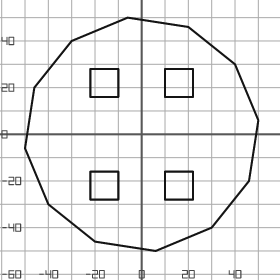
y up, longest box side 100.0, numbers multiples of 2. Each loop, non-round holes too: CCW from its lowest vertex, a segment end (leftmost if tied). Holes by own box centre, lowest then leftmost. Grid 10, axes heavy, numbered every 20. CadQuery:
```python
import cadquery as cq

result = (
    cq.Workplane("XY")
    .moveTo(6.0, -50.0)
    .lineTo(30.0, -40.0)
    .lineTo(46.0, -20.0)
    .lineTo(50.0, 6.0)
    .lineTo(40.0, 30.0)
    .lineTo(20.0, 46.0)
    .lineTo(-6.0, 50.0)
    .lineTo(-30.0, 40.0)
    .lineTo(-46.0, 20.0)
    .lineTo(-50.0, -6.0)
    .lineTo(-40.0, -30.0)
    .lineTo(-20.0, -46.0)
    .close()
    .moveTo(-22.0, -28.0)
    .lineTo(-10.0, -28.0)
    .lineTo(-10.0, -16.0)
    .lineTo(-22.0, -16.0)
    .close()
    .moveTo(10.0, -28.0)
    .lineTo(22.0, -28.0)
    .lineTo(22.0, -16.0)
    .lineTo(10.0, -16.0)
    .close()
    .moveTo(-22.0, 16.0)
    .lineTo(-10.0, 16.0)
    .lineTo(-10.0, 28.0)
    .lineTo(-22.0, 28.0)
    .close()
    .moveTo(10.0, 16.0)
    .lineTo(22.0, 16.0)
    .lineTo(22.0, 28.0)
    .lineTo(10.0, 28.0)
    .close()
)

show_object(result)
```